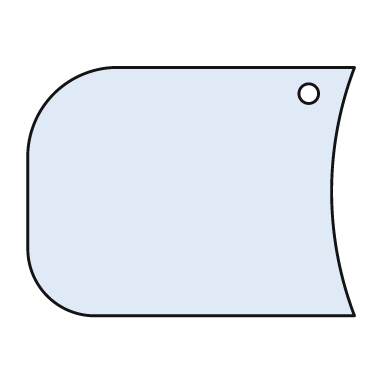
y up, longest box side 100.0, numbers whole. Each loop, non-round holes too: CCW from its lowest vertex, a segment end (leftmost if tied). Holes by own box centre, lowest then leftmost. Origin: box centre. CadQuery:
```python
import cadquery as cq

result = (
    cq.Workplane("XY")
    .moveTo(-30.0, -38.0)
    .lineTo(50.0, -38.0)
    .threePointArc((43.0, 0.0), (50.0, 38.0))
    .lineTo(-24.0, 38.0)
    .threePointArc((-42.0, 30.0), (-50.0, 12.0))
    .lineTo(-50.0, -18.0)
    .threePointArc((-44.0, -32.0), (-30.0, -38.0))
    .close()
    .moveTo(36.0, 30.0)
    .circle(3.0)
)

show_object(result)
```